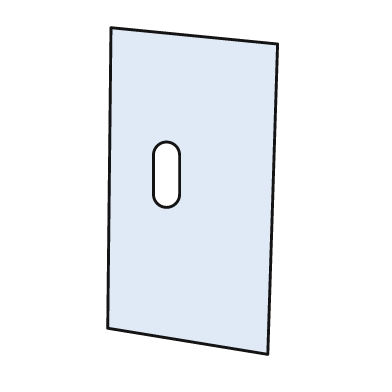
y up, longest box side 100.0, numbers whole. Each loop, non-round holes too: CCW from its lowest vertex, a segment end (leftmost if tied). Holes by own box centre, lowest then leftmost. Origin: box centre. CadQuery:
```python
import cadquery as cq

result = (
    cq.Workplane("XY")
    .moveTo(23.0, -50.0)
    .lineTo(26.0, 45.0)
    .lineTo(-25.0, 50.0)
    .lineTo(-26.0, -42.0)
    .close()
    .moveTo(-12.0, -1.0)
    .threePointArc((-8.0, -5.0), (-4.0, -1.0))
    .lineTo(-4.0, 11.0)
    .threePointArc((-8.0, 15.0), (-12.0, 11.0))
    .close()
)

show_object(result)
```